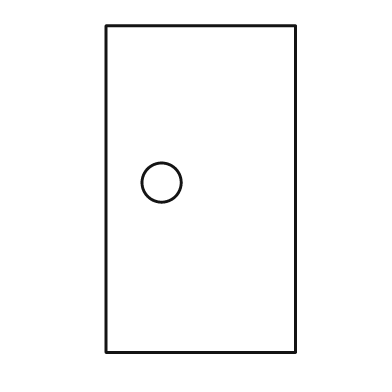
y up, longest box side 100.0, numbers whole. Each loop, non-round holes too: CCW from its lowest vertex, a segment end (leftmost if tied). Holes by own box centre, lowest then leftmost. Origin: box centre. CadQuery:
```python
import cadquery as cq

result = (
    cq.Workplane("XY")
    .moveTo(-29.0, -50.0)
    .lineTo(29.0, -50.0)
    .lineTo(29.0, 50.0)
    .lineTo(-29.0, 50.0)
    .close()
    .moveTo(-12.0, 2.0)
    .circle(6.0)
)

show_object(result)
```